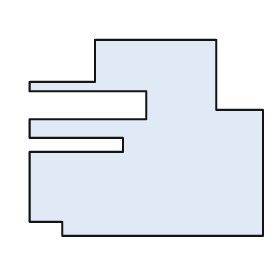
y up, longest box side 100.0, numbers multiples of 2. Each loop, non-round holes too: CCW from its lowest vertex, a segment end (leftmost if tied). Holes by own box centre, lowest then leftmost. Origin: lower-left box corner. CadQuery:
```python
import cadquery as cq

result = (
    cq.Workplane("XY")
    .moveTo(14.0, 0.0)
    .lineTo(100.0, 0.0)
    .lineTo(100.0, 54.0)
    .lineTo(80.0, 54.0)
    .lineTo(80.0, 84.0)
    .lineTo(28.0, 84.0)
    .lineTo(28.0, 66.0)
    .lineTo(0.0, 66.0)
    .lineTo(0.0, 62.0)
    .lineTo(50.0, 62.0)
    .lineTo(50.0, 50.0)
    .lineTo(0.0, 50.0)
    .lineTo(0.0, 42.0)
    .lineTo(40.0, 42.0)
    .lineTo(40.0, 36.0)
    .lineTo(0.0, 36.0)
    .lineTo(0.0, 6.0)
    .lineTo(14.0, 6.0)
    .close()
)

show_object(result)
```